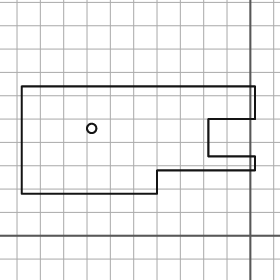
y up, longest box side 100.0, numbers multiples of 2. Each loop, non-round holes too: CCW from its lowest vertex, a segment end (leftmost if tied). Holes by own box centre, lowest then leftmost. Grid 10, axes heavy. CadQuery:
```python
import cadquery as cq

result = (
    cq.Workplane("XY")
    .moveTo(-98.0, 18.0)
    .lineTo(-40.0, 18.0)
    .lineTo(-40.0, 28.0)
    .lineTo(2.0, 28.0)
    .lineTo(2.0, 34.0)
    .lineTo(-18.0, 34.0)
    .lineTo(-18.0, 50.0)
    .lineTo(2.0, 50.0)
    .lineTo(2.0, 64.0)
    .lineTo(-98.0, 64.0)
    .close()
    .moveTo(-68.0, 46.0)
    .circle(2.0)
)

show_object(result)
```